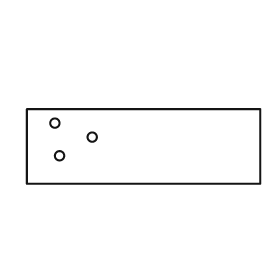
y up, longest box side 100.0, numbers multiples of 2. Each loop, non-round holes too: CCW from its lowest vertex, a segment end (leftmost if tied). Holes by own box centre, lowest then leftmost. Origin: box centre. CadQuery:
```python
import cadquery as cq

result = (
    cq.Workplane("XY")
    .moveTo(-50.0, -16.0)
    .lineTo(50.0, -16.0)
    .lineTo(50.0, 16.0)
    .lineTo(-50.0, 16.0)
    .close()
    .moveTo(-36.0, -4.0)
    .circle(2.0)
    .moveTo(-22.0, 4.0)
    .circle(2.0)
    .moveTo(-38.0, 10.0)
    .circle(2.0)
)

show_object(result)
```